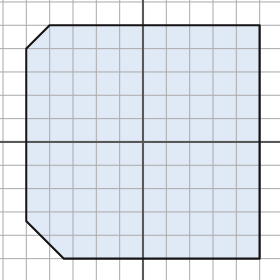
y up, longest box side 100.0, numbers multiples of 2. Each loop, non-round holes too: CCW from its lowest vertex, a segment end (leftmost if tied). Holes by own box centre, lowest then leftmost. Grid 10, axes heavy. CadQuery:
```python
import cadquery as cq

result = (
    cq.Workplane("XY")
    .moveTo(-34.0, -50.0)
    .lineTo(50.0, -50.0)
    .lineTo(50.0, 50.0)
    .lineTo(-40.0, 50.0)
    .lineTo(-50.0, 40.0)
    .lineTo(-50.0, -34.0)
    .close()
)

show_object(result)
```